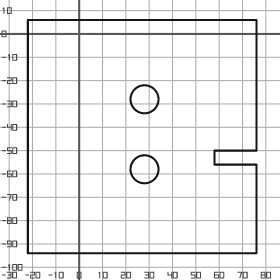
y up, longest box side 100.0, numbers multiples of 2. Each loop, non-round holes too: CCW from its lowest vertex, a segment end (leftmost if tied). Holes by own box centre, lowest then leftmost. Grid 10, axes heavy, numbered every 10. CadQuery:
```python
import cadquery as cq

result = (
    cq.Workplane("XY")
    .moveTo(-22.0, -94.0)
    .lineTo(76.0, -94.0)
    .lineTo(76.0, -56.0)
    .lineTo(58.0, -56.0)
    .lineTo(58.0, -50.0)
    .lineTo(76.0, -50.0)
    .lineTo(76.0, 6.0)
    .lineTo(-22.0, 6.0)
    .close()
    .moveTo(28.0, -58.0)
    .circle(6.0)
    .moveTo(28.0, -28.0)
    .circle(6.0)
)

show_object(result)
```